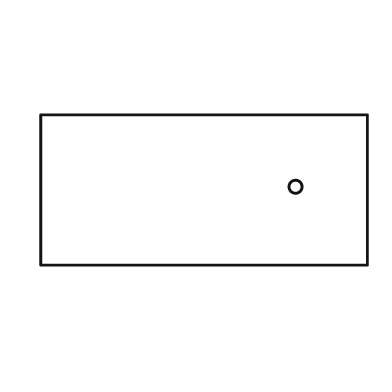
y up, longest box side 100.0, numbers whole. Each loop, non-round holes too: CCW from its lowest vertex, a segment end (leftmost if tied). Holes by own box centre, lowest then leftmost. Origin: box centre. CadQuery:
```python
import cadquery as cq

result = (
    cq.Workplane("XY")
    .moveTo(-50.0, -23.0)
    .lineTo(50.0, -23.0)
    .lineTo(50.0, 23.0)
    .lineTo(-50.0, 23.0)
    .close()
    .moveTo(28.0, 1.0)
    .circle(2.0)
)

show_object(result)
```